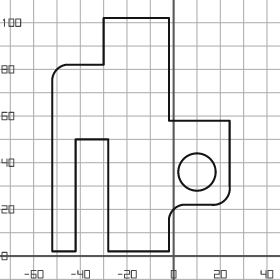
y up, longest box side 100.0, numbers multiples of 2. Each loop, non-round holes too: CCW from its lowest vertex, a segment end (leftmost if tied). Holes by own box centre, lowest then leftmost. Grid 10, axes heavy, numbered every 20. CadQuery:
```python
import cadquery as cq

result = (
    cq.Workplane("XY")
    .moveTo(-52.0, 2.0)
    .lineTo(-42.0, 2.0)
    .lineTo(-42.0, 50.0)
    .lineTo(-28.0, 50.0)
    .lineTo(-28.0, 2.0)
    .lineTo(-2.0, 2.0)
    .lineTo(-2.0, 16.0)
    .threePointArc((0.0, 20.0), (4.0, 22.0))
    .lineTo(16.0, 22.0)
    .threePointArc((22.0, 24.0), (24.0, 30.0))
    .lineTo(24.0, 58.0)
    .lineTo(-2.0, 58.0)
    .lineTo(-2.0, 102.0)
    .lineTo(-30.0, 102.0)
    .lineTo(-30.0, 82.0)
    .lineTo(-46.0, 82.0)
    .threePointArc((-50.0, 80.0), (-52.0, 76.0))
    .close()
    .moveTo(10.0, 36.0)
    .circle(8.0)
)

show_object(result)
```